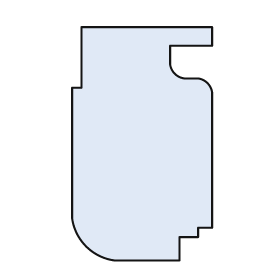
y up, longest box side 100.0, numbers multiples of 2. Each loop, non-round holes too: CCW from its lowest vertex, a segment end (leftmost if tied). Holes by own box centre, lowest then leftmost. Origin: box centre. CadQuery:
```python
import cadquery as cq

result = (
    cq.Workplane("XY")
    .moveTo(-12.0, -50.0)
    .lineTo(16.0, -50.0)
    .lineTo(16.0, -40.0)
    .lineTo(24.0, -40.0)
    .lineTo(24.0, -36.0)
    .lineTo(30.0, -36.0)
    .lineTo(30.0, 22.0)
    .threePointArc((28.0, 26.0), (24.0, 28.0))
    .lineTo(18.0, 28.0)
    .threePointArc((14.0, 30.0), (12.0, 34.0))
    .lineTo(12.0, 42.0)
    .lineTo(30.0, 42.0)
    .lineTo(30.0, 50.0)
    .lineTo(-26.0, 50.0)
    .lineTo(-26.0, 24.0)
    .lineTo(-30.0, 24.0)
    .lineTo(-30.0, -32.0)
    .threePointArc((-24.0, -44.0), (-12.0, -50.0))
    .close()
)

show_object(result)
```